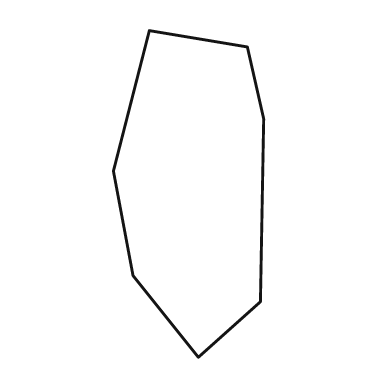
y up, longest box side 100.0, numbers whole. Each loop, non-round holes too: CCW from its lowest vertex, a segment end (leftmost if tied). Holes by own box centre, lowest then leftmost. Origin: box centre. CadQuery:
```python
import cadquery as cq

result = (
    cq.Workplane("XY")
    .moveTo(3.0, -50.0)
    .lineTo(22.0, -33.0)
    .lineTo(23.0, 23.0)
    .lineTo(18.0, 45.0)
    .lineTo(-12.0, 50.0)
    .lineTo(-23.0, 7.0)
    .lineTo(-17.0, -25.0)
    .close()
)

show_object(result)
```